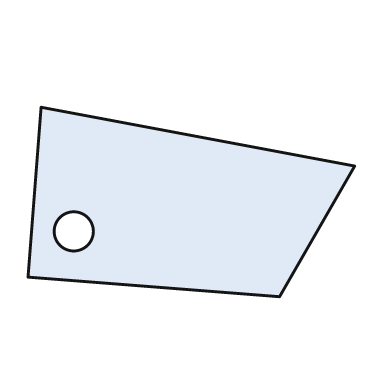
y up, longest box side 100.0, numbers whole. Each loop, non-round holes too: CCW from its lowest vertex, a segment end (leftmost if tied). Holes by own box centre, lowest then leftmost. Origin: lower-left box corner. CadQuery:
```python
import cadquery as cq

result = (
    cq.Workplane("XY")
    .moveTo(77.0, 0.0)
    .lineTo(100.0, 40.0)
    .lineTo(4.0, 58.0)
    .lineTo(0.0, 6.0)
    .close()
    .moveTo(14.0, 20.0)
    .circle(6.0)
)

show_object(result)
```